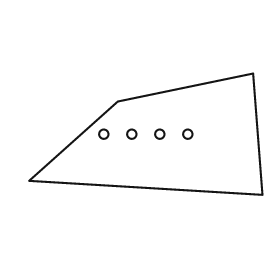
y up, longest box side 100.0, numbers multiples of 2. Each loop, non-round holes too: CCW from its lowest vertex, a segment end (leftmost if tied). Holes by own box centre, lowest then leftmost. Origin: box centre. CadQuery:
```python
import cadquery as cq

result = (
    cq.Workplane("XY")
    .moveTo(50.0, -26.0)
    .lineTo(46.0, 26.0)
    .lineTo(-12.0, 14.0)
    .lineTo(-50.0, -20.0)
    .close()
    .moveTo(-18.0, 0.0)
    .circle(2.0)
    .moveTo(-6.0, 0.0)
    .circle(2.0)
    .moveTo(6.0, 0.0)
    .circle(2.0)
    .moveTo(18.0, 0.0)
    .circle(2.0)
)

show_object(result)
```